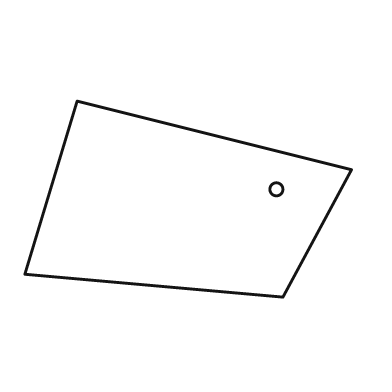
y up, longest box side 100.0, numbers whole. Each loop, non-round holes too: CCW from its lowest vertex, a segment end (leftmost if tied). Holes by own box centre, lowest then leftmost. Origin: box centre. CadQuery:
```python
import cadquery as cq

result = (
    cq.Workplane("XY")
    .moveTo(29.0, -30.0)
    .lineTo(50.0, 9.0)
    .lineTo(-34.0, 30.0)
    .lineTo(-50.0, -23.0)
    .close()
    .moveTo(27.0, 3.0)
    .circle(2.0)
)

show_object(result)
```